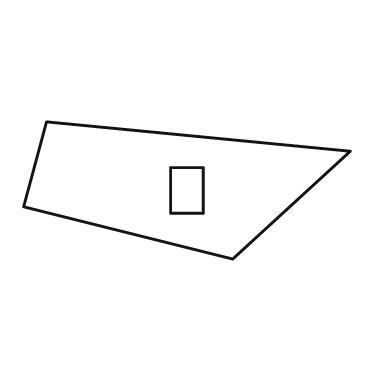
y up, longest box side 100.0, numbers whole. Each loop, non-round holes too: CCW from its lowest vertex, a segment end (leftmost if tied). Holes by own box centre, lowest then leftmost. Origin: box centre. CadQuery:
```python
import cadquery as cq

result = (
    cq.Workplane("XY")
    .moveTo(14.0, -21.0)
    .lineTo(50.0, 12.0)
    .lineTo(-43.0, 21.0)
    .lineTo(-50.0, -5.0)
    .close()
    .moveTo(-5.0, -7.0)
    .lineTo(5.0, -7.0)
    .lineTo(5.0, 7.0)
    .lineTo(-5.0, 7.0)
    .close()
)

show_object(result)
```